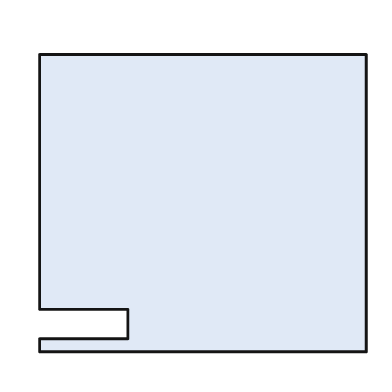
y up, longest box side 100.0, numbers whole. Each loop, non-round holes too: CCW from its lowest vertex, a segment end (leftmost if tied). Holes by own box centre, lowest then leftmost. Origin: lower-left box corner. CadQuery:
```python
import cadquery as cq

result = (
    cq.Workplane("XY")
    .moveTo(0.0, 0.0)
    .lineTo(100.0, 0.0)
    .lineTo(100.0, 91.0)
    .lineTo(0.0, 91.0)
    .lineTo(0.0, 13.0)
    .lineTo(27.0, 13.0)
    .lineTo(27.0, 4.0)
    .lineTo(0.0, 4.0)
    .close()
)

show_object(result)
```